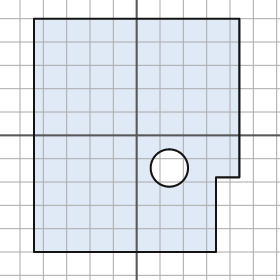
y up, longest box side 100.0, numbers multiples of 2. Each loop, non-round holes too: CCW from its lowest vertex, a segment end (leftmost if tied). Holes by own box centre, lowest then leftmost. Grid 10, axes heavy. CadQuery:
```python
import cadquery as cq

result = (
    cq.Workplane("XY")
    .moveTo(-44.0, -50.0)
    .lineTo(34.0, -50.0)
    .lineTo(34.0, -18.0)
    .lineTo(44.0, -18.0)
    .lineTo(44.0, 50.0)
    .lineTo(-44.0, 50.0)
    .close()
    .moveTo(14.0, -14.0)
    .circle(8.0)
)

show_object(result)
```